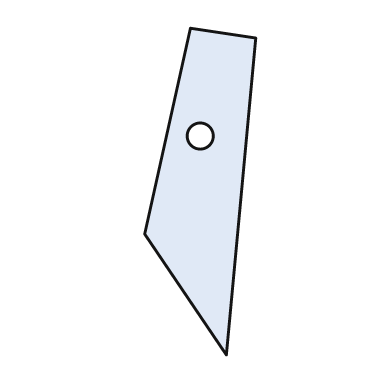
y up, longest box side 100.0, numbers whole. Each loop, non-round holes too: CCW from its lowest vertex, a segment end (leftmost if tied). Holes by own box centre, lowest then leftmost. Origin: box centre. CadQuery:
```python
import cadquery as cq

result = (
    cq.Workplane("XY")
    .moveTo(8.0, -50.0)
    .lineTo(17.0, 47.0)
    .lineTo(-3.0, 50.0)
    .lineTo(-17.0, -13.0)
    .close()
    .moveTo(0.0, 17.0)
    .circle(4.0)
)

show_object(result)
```